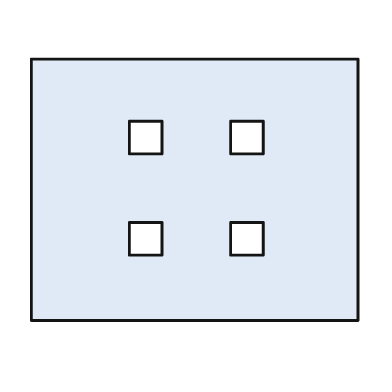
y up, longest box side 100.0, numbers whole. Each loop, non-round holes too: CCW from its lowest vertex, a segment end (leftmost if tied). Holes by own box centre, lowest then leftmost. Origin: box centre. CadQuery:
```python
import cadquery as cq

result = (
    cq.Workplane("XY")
    .moveTo(-50.0, -40.0)
    .lineTo(50.0, -40.0)
    .lineTo(50.0, 40.0)
    .lineTo(-50.0, 40.0)
    .close()
    .moveTo(-20.0, -20.0)
    .lineTo(-10.0, -20.0)
    .lineTo(-10.0, -10.0)
    .lineTo(-20.0, -10.0)
    .close()
    .moveTo(11.0, -20.0)
    .lineTo(21.0, -20.0)
    .lineTo(21.0, -10.0)
    .lineTo(11.0, -10.0)
    .close()
    .moveTo(-20.0, 11.0)
    .lineTo(-10.0, 11.0)
    .lineTo(-10.0, 21.0)
    .lineTo(-20.0, 21.0)
    .close()
    .moveTo(11.0, 11.0)
    .lineTo(21.0, 11.0)
    .lineTo(21.0, 21.0)
    .lineTo(11.0, 21.0)
    .close()
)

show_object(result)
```